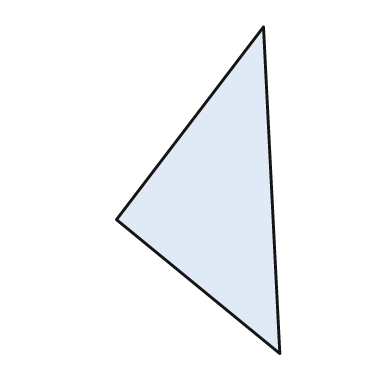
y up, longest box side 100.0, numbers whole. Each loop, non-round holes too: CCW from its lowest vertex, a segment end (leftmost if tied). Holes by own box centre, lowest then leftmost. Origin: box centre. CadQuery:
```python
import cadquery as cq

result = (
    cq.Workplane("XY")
    .moveTo(25.0, -50.0)
    .lineTo(20.0, 50.0)
    .lineTo(-25.0, -9.0)
    .close()
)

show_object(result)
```